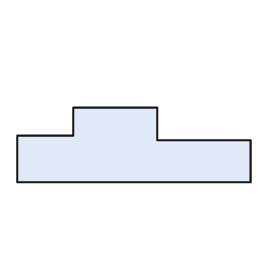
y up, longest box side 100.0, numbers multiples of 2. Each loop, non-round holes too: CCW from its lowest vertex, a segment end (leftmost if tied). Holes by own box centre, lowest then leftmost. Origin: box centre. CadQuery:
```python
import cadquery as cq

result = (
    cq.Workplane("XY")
    .moveTo(-50.0, -16.0)
    .lineTo(50.0, -16.0)
    .lineTo(50.0, 2.0)
    .lineTo(10.0, 2.0)
    .lineTo(10.0, 16.0)
    .lineTo(-26.0, 16.0)
    .lineTo(-26.0, 4.0)
    .lineTo(-50.0, 4.0)
    .close()
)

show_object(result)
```